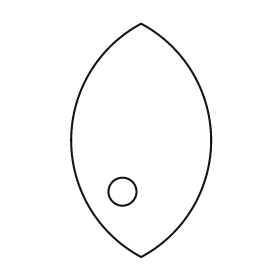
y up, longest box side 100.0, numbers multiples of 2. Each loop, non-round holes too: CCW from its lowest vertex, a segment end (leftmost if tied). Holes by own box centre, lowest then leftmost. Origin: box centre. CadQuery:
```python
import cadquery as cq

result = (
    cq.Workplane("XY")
    .moveTo(0.0, -50.0)
    .threePointArc((30.0, 0.0), (0.0, 50.0))
    .threePointArc((-30.0, 0.0), (0.0, -50.0))
    .close()
    .moveTo(-8.0, -22.0)
    .circle(6.0)
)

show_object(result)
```